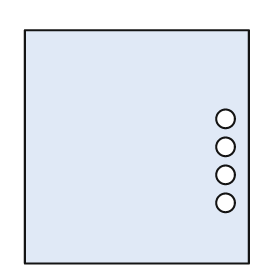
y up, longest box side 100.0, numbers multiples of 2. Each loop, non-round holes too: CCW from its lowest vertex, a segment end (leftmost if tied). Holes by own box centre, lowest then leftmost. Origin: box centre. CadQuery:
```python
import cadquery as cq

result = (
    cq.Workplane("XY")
    .moveTo(-48.0, -50.0)
    .lineTo(48.0, -50.0)
    .lineTo(48.0, 50.0)
    .lineTo(-48.0, 50.0)
    .close()
    .moveTo(38.0, -24.0)
    .circle(4.0)
    .moveTo(38.0, -12.0)
    .circle(4.0)
    .moveTo(38.0, 0.0)
    .circle(4.0)
    .moveTo(38.0, 12.0)
    .circle(4.0)
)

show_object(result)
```